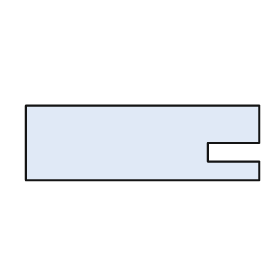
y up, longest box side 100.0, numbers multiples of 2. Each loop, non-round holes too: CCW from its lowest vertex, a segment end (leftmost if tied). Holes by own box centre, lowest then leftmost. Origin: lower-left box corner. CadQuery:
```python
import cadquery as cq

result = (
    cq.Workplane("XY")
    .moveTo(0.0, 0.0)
    .lineTo(100.0, 0.0)
    .lineTo(100.0, 8.0)
    .lineTo(78.0, 8.0)
    .lineTo(78.0, 16.0)
    .lineTo(100.0, 16.0)
    .lineTo(100.0, 32.0)
    .lineTo(0.0, 32.0)
    .close()
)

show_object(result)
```